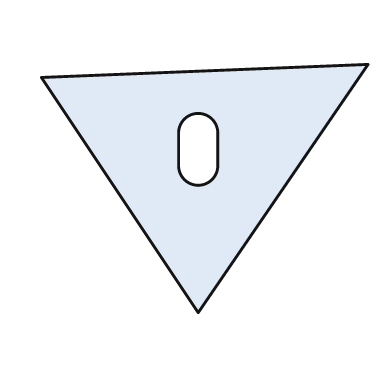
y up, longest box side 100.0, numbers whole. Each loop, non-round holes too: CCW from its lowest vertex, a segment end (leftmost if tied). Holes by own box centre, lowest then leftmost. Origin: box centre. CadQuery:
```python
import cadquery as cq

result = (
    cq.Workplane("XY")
    .moveTo(-2.0, -38.0)
    .lineTo(50.0, 38.0)
    .lineTo(-50.0, 34.0)
    .close()
    .moveTo(-8.0, 7.0)
    .threePointArc((-2.0, 1.0), (4.0, 7.0))
    .lineTo(4.0, 17.0)
    .threePointArc((-2.0, 23.0), (-8.0, 17.0))
    .close()
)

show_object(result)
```